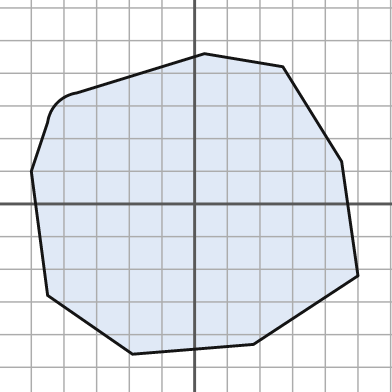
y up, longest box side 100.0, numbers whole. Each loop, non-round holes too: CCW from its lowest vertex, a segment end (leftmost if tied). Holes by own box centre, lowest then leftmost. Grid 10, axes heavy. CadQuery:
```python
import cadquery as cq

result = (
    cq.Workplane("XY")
    .moveTo(-19.0, -46.0)
    .lineTo(18.0, -43.0)
    .lineTo(50.0, -22.0)
    .lineTo(45.0, 13.0)
    .lineTo(27.0, 42.0)
    .lineTo(3.0, 46.0)
    .lineTo(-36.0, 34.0)
    .threePointArc((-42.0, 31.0), (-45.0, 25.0))
    .lineTo(-50.0, 10.0)
    .lineTo(-45.0, -28.0)
    .close()
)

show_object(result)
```